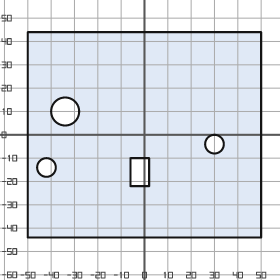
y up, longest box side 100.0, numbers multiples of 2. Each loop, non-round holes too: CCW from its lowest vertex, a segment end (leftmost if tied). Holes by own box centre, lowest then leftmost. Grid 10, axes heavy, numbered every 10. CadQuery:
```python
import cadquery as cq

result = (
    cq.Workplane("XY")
    .moveTo(-50.0, -44.0)
    .lineTo(50.0, -44.0)
    .lineTo(50.0, 44.0)
    .lineTo(-50.0, 44.0)
    .close()
    .moveTo(-6.0, -22.0)
    .lineTo(2.0, -22.0)
    .lineTo(2.0, -10.0)
    .lineTo(-6.0, -10.0)
    .close()
    .moveTo(-42.0, -14.0)
    .circle(4.0)
    .moveTo(30.0, -4.0)
    .circle(4.0)
    .moveTo(-34.0, 10.0)
    .circle(6.0)
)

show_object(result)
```